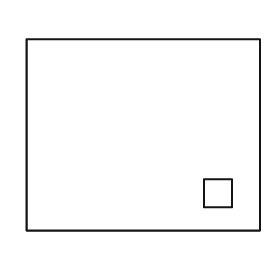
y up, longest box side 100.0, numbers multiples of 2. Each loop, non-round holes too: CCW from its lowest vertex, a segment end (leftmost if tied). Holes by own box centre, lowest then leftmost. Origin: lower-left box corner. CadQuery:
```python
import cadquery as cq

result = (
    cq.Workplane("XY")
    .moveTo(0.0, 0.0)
    .lineTo(100.0, 0.0)
    .lineTo(100.0, 82.0)
    .lineTo(0.0, 82.0)
    .close()
    .moveTo(76.0, 10.0)
    .lineTo(88.0, 10.0)
    .lineTo(88.0, 22.0)
    .lineTo(76.0, 22.0)
    .close()
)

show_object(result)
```